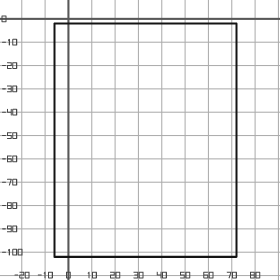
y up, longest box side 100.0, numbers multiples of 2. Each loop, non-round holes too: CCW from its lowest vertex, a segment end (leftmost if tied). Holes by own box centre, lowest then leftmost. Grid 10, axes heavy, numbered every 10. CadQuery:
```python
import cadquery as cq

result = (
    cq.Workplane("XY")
    .moveTo(-6.0, -102.0)
    .lineTo(72.0, -102.0)
    .lineTo(72.0, -2.0)
    .lineTo(-6.0, -2.0)
    .close()
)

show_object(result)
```